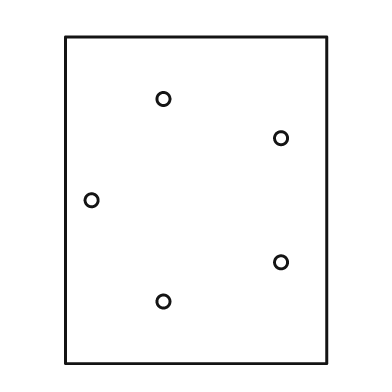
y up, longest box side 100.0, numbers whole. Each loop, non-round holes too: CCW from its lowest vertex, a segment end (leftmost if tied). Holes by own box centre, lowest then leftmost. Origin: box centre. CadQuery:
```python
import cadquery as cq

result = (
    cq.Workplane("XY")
    .moveTo(-40.0, -50.0)
    .lineTo(40.0, -50.0)
    .lineTo(40.0, 50.0)
    .lineTo(-40.0, 50.0)
    .close()
    .moveTo(-10.0, -31.0)
    .circle(2.0)
    .moveTo(26.0, -19.0)
    .circle(2.0)
    .moveTo(-32.0, 0.0)
    .circle(2.0)
    .moveTo(26.0, 19.0)
    .circle(2.0)
    .moveTo(-10.0, 31.0)
    .circle(2.0)
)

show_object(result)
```